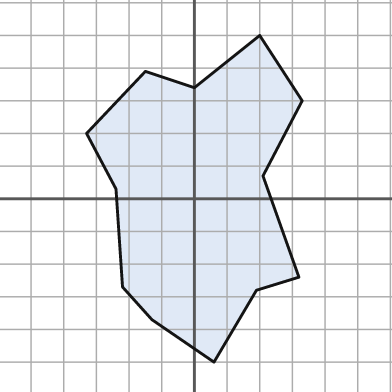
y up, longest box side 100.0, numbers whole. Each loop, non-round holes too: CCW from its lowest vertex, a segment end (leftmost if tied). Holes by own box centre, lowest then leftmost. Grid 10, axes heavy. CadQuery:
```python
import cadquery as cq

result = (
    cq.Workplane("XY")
    .moveTo(6.0, -50.0)
    .lineTo(19.0, -28.0)
    .lineTo(32.0, -24.0)
    .lineTo(21.0, 7.0)
    .lineTo(33.0, 30.0)
    .lineTo(20.0, 50.0)
    .lineTo(0.0, 34.0)
    .lineTo(-15.0, 39.0)
    .lineTo(-33.0, 20.0)
    .lineTo(-24.0, 3.0)
    .lineTo(-22.0, -27.0)
    .lineTo(-13.0, -37.0)
    .close()
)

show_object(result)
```